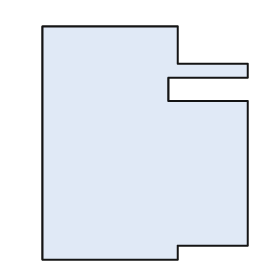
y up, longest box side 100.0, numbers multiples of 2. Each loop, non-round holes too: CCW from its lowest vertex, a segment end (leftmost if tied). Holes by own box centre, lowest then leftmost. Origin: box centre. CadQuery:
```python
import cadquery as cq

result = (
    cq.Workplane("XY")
    .moveTo(-44.0, -50.0)
    .lineTo(14.0, -50.0)
    .lineTo(14.0, -44.0)
    .lineTo(44.0, -44.0)
    .lineTo(44.0, 18.0)
    .lineTo(10.0, 18.0)
    .lineTo(10.0, 28.0)
    .lineTo(44.0, 28.0)
    .lineTo(44.0, 34.0)
    .lineTo(14.0, 34.0)
    .lineTo(14.0, 50.0)
    .lineTo(-44.0, 50.0)
    .close()
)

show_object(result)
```